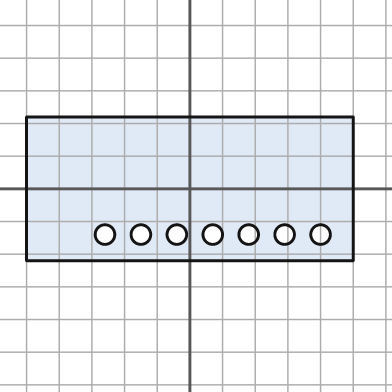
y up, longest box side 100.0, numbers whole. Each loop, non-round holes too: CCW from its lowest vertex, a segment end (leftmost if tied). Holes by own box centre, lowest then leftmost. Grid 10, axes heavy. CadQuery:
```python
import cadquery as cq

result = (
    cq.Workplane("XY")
    .moveTo(-50.0, -22.0)
    .lineTo(50.0, -22.0)
    .lineTo(50.0, 22.0)
    .lineTo(-50.0, 22.0)
    .close()
    .moveTo(-26.0, -14.0)
    .circle(3.0)
    .moveTo(-15.0, -14.0)
    .circle(3.0)
    .moveTo(-4.0, -14.0)
    .circle(3.0)
    .moveTo(7.0, -14.0)
    .circle(3.0)
    .moveTo(18.0, -14.0)
    .circle(3.0)
    .moveTo(29.0, -14.0)
    .circle(3.0)
    .moveTo(40.0, -14.0)
    .circle(3.0)
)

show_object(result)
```